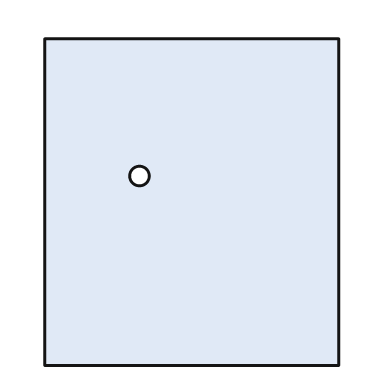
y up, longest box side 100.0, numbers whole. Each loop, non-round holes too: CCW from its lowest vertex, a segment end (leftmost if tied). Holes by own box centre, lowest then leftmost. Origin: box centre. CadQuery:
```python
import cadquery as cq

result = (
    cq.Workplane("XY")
    .moveTo(-45.0, -50.0)
    .lineTo(45.0, -50.0)
    .lineTo(45.0, 50.0)
    .lineTo(-45.0, 50.0)
    .close()
    .moveTo(-16.0, 8.0)
    .circle(3.0)
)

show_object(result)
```